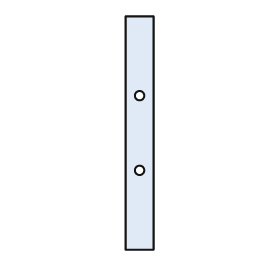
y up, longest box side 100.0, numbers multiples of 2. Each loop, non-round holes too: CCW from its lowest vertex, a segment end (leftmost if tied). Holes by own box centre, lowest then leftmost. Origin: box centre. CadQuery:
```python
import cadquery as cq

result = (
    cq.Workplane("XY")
    .moveTo(-6.0, -50.0)
    .lineTo(6.0, -50.0)
    .lineTo(6.0, 50.0)
    .lineTo(-6.0, 50.0)
    .close()
    .moveTo(0.0, -16.0)
    .circle(2.0)
    .moveTo(0.0, 16.0)
    .circle(2.0)
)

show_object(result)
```